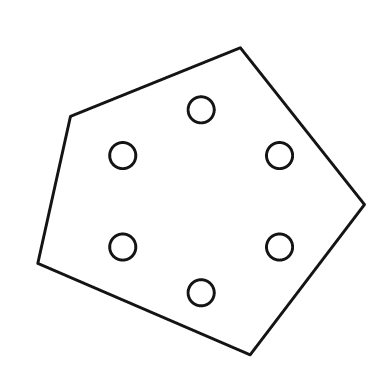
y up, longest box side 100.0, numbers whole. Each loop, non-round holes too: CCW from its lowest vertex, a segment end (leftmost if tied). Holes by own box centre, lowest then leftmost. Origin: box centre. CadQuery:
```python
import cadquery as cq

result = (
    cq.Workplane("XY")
    .moveTo(15.0, -47.0)
    .lineTo(50.0, -1.0)
    .lineTo(12.0, 47.0)
    .lineTo(-40.0, 26.0)
    .lineTo(-50.0, -19.0)
    .close()
    .moveTo(0.0, -28.0)
    .circle(4.0)
    .moveTo(-24.0, -14.0)
    .circle(4.0)
    .moveTo(24.0, -14.0)
    .circle(4.0)
    .moveTo(-24.0, 14.0)
    .circle(4.0)
    .moveTo(24.0, 14.0)
    .circle(4.0)
    .moveTo(0.0, 28.0)
    .circle(4.0)
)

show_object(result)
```